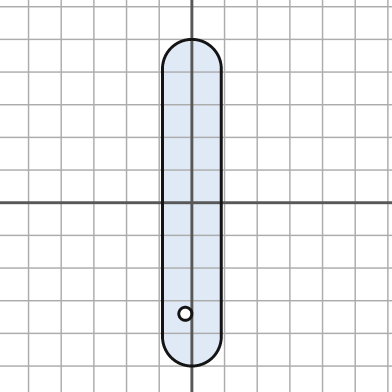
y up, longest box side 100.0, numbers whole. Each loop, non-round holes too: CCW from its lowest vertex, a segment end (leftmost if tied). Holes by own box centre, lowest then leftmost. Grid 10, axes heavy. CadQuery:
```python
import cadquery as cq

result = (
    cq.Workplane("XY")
    .moveTo(-9.0, -41.0)
    .threePointArc((0.0, -50.0), (9.0, -41.0))
    .lineTo(9.0, 41.0)
    .threePointArc((0.0, 50.0), (-9.0, 41.0))
    .close()
    .moveTo(-2.0, -34.0)
    .circle(2.0)
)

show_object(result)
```